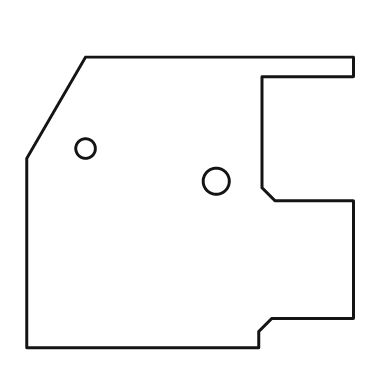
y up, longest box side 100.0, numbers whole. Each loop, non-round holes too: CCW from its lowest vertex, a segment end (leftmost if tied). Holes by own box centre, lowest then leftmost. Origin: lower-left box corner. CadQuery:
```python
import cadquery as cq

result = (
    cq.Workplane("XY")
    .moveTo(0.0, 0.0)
    .lineTo(71.0, 0.0)
    .lineTo(71.0, 5.0)
    .lineTo(75.0, 9.0)
    .lineTo(100.0, 9.0)
    .lineTo(100.0, 45.0)
    .lineTo(76.0, 45.0)
    .lineTo(72.0, 49.0)
    .lineTo(72.0, 83.0)
    .lineTo(100.0, 83.0)
    .lineTo(100.0, 89.0)
    .lineTo(18.0, 89.0)
    .lineTo(0.0, 58.0)
    .close()
    .moveTo(58.0, 51.0)
    .circle(4.0)
    .moveTo(18.0, 61.0)
    .circle(3.0)
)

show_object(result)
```